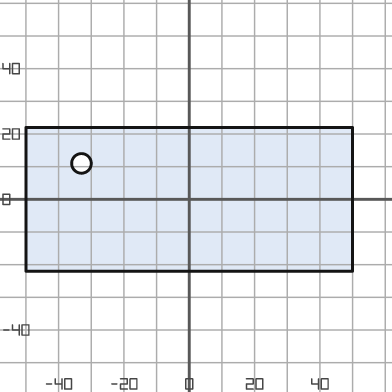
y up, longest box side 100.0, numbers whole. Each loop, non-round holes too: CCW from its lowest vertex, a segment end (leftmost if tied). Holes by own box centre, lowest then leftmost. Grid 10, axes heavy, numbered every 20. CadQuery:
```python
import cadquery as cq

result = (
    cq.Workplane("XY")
    .moveTo(-50.0, -22.0)
    .lineTo(50.0, -22.0)
    .lineTo(50.0, 22.0)
    .lineTo(-50.0, 22.0)
    .close()
    .moveTo(-33.0, 11.0)
    .circle(3.0)
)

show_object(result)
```